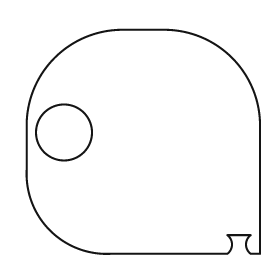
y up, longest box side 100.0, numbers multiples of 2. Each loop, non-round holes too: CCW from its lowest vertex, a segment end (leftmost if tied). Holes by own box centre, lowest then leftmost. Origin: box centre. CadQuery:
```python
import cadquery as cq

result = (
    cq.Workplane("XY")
    .moveTo(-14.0, -48.0)
    .lineTo(36.0, -48.0)
    .threePointArc((38.0, -44.0), (36.0, -40.0))
    .lineTo(46.0, -40.0)
    .threePointArc((44.0, -44.0), (46.0, -48.0))
    .lineTo(50.0, -48.0)
    .lineTo(50.0, 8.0)
    .threePointArc((38.0, 36.0), (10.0, 48.0))
    .lineTo(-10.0, 48.0)
    .threePointArc((-38.0, 36.0), (-50.0, 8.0))
    .lineTo(-50.0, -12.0)
    .threePointArc((-40.0, -38.0), (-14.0, -48.0))
    .close()
    .moveTo(-34.0, 4.0)
    .circle(12.0)
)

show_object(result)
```